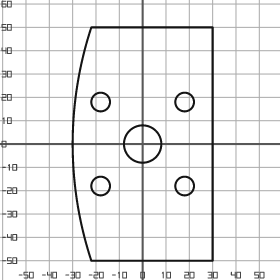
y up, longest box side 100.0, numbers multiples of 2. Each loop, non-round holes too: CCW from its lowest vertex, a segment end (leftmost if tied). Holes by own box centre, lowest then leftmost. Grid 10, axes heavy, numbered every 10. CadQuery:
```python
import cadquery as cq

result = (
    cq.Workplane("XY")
    .moveTo(-22.0, -50.0)
    .lineTo(30.0, -50.0)
    .lineTo(30.0, 50.0)
    .lineTo(-22.0, 50.0)
    .threePointArc((-30.0, 0.0), (-22.0, -50.0))
    .close()
    .moveTo(-18.0, -18.0)
    .circle(4.0)
    .moveTo(18.0, -18.0)
    .circle(4.0)
    .moveTo(0.0, 0.0)
    .circle(8.0)
    .moveTo(-18.0, 18.0)
    .circle(4.0)
    .moveTo(18.0, 18.0)
    .circle(4.0)
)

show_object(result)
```